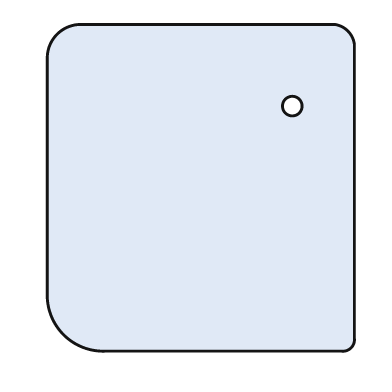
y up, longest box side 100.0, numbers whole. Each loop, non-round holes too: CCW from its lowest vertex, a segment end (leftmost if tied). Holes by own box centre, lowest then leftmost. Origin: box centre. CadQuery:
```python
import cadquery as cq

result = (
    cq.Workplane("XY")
    .moveTo(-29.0, -50.0)
    .lineTo(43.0, -50.0)
    .threePointArc((46.0, -49.0), (47.0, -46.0))
    .lineTo(47.0, 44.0)
    .threePointArc((45.0, 48.0), (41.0, 50.0))
    .lineTo(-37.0, 50.0)
    .threePointArc((-44.0, 47.0), (-47.0, 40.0))
    .lineTo(-47.0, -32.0)
    .threePointArc((-42.0, -45.0), (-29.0, -50.0))
    .close()
    .moveTo(28.0, 25.0)
    .circle(3.0)
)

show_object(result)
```